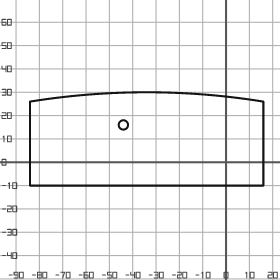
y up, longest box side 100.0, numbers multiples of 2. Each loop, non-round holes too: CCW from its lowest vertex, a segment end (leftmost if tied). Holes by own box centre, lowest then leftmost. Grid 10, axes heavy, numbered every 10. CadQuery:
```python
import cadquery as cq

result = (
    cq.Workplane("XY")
    .moveTo(-84.0, -10.0)
    .lineTo(16.0, -10.0)
    .lineTo(16.0, 26.0)
    .threePointArc((-34.0, 30.0), (-84.0, 26.0))
    .close()
    .moveTo(-44.0, 16.0)
    .circle(2.0)
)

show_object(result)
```